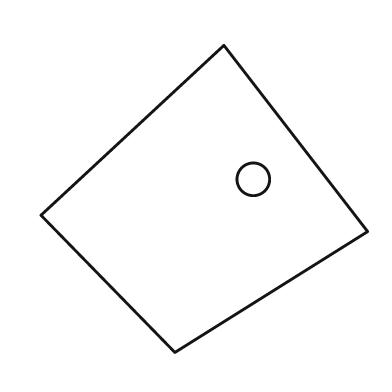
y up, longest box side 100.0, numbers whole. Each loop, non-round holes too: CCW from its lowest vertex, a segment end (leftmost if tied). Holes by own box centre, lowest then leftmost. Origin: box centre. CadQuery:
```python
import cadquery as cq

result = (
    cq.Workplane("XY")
    .moveTo(-9.0, -47.0)
    .lineTo(50.0, -10.0)
    .lineTo(6.0, 47.0)
    .lineTo(-50.0, -5.0)
    .close()
    .moveTo(15.0, 6.0)
    .circle(5.0)
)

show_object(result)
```